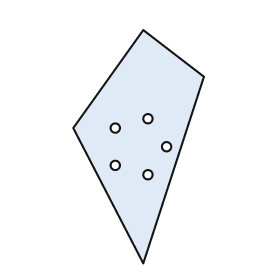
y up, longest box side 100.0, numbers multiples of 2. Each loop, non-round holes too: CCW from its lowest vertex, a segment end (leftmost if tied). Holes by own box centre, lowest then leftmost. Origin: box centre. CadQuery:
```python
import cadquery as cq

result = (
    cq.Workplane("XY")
    .moveTo(2.0, -50.0)
    .lineTo(28.0, 30.0)
    .lineTo(2.0, 50.0)
    .lineTo(-28.0, 8.0)
    .close()
    .moveTo(4.0, -12.0)
    .circle(2.0)
    .moveTo(-10.0, -8.0)
    .circle(2.0)
    .moveTo(12.0, 0.0)
    .circle(2.0)
    .moveTo(-10.0, 8.0)
    .circle(2.0)
    .moveTo(4.0, 12.0)
    .circle(2.0)
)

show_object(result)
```